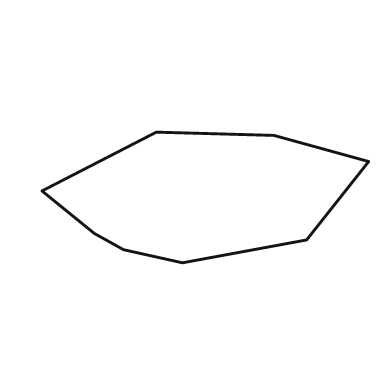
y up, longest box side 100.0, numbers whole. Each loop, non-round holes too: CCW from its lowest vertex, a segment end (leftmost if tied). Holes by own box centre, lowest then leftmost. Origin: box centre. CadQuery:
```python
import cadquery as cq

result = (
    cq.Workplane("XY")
    .moveTo(-7.0, -20.0)
    .lineTo(31.0, -13.0)
    .lineTo(50.0, 11.0)
    .lineTo(21.0, 19.0)
    .lineTo(-15.0, 20.0)
    .lineTo(-50.0, 2.0)
    .lineTo(-34.0, -11.0)
    .lineTo(-25.0, -16.0)
    .close()
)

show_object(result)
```